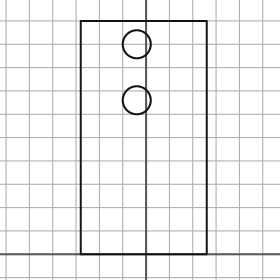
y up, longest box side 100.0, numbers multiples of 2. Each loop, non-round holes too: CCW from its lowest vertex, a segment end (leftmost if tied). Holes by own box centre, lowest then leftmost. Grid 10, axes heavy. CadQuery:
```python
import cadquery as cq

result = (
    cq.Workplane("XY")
    .moveTo(-28.0, 0.0)
    .lineTo(26.0, 0.0)
    .lineTo(26.0, 100.0)
    .lineTo(-28.0, 100.0)
    .close()
    .moveTo(-4.0, 66.0)
    .circle(6.0)
    .moveTo(-4.0, 90.0)
    .circle(6.0)
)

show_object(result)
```